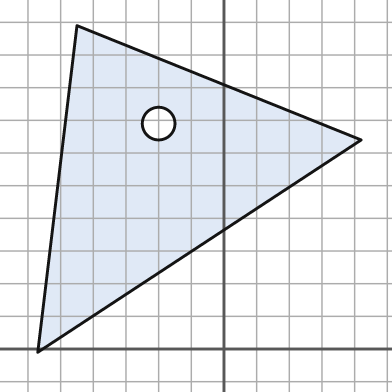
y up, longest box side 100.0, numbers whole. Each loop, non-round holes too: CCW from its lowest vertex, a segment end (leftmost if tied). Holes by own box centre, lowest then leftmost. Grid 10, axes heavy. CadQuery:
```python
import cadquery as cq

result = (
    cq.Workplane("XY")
    .moveTo(-57.0, -1.0)
    .lineTo(42.0, 64.0)
    .lineTo(-45.0, 99.0)
    .close()
    .moveTo(-20.0, 69.0)
    .circle(5.0)
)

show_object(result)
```